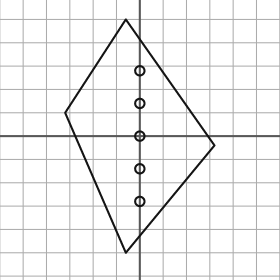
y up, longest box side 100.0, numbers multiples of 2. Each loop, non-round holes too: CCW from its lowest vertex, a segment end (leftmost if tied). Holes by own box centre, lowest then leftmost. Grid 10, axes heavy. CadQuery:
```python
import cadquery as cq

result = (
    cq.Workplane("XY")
    .moveTo(-6.0, -50.0)
    .lineTo(32.0, -4.0)
    .lineTo(-6.0, 50.0)
    .lineTo(-32.0, 10.0)
    .close()
    .moveTo(0.0, -28.0)
    .circle(2.0)
    .moveTo(0.0, -14.0)
    .circle(2.0)
    .moveTo(0.0, 0.0)
    .circle(2.0)
    .moveTo(0.0, 14.0)
    .circle(2.0)
    .moveTo(0.0, 28.0)
    .circle(2.0)
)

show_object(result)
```